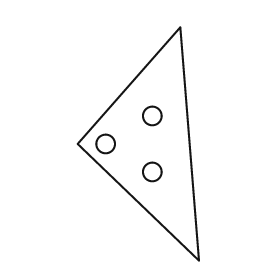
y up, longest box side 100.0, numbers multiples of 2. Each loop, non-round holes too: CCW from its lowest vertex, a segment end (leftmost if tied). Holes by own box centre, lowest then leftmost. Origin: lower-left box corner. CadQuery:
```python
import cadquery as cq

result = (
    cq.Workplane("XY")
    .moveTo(52.0, 0.0)
    .lineTo(44.0, 100.0)
    .lineTo(0.0, 50.0)
    .close()
    .moveTo(32.0, 38.0)
    .circle(4.0)
    .moveTo(12.0, 50.0)
    .circle(4.0)
    .moveTo(32.0, 62.0)
    .circle(4.0)
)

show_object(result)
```